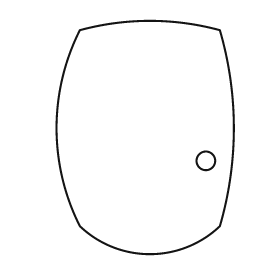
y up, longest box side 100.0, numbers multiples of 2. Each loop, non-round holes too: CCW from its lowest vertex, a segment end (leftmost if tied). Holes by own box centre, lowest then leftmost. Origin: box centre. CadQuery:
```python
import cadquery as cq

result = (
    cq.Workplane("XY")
    .moveTo(-28.0, -38.0)
    .threePointArc((2.0, -50.0), (32.0, -38.0))
    .threePointArc((38.0, 4.0), (32.0, 46.0))
    .threePointArc((2.0, 50.0), (-28.0, 46.0))
    .threePointArc((-38.0, 4.0), (-28.0, -38.0))
    .close()
    .moveTo(26.0, -10.0)
    .circle(4.0)
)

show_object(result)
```